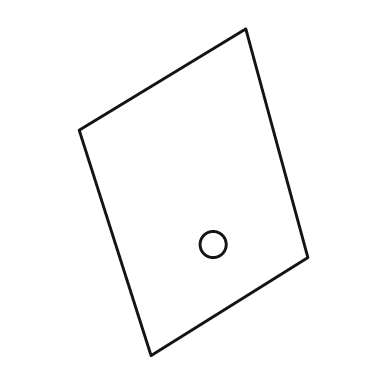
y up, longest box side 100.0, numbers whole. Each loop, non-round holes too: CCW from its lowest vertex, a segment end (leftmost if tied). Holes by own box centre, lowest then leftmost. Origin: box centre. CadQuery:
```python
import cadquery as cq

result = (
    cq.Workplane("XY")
    .moveTo(-13.0, -50.0)
    .lineTo(35.0, -20.0)
    .lineTo(16.0, 50.0)
    .lineTo(-35.0, 19.0)
    .close()
    .moveTo(6.0, -16.0)
    .circle(4.0)
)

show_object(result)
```